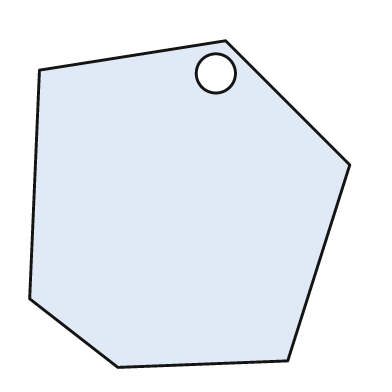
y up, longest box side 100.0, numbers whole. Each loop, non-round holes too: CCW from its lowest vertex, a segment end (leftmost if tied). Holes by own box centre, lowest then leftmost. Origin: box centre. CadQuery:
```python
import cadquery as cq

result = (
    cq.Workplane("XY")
    .moveTo(-22.0, -50.0)
    .lineTo(30.0, -48.0)
    .lineTo(49.0, 12.0)
    .lineTo(11.0, 50.0)
    .lineTo(-46.0, 41.0)
    .lineTo(-49.0, -29.0)
    .close()
    .moveTo(8.0, 40.0)
    .circle(6.0)
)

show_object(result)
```